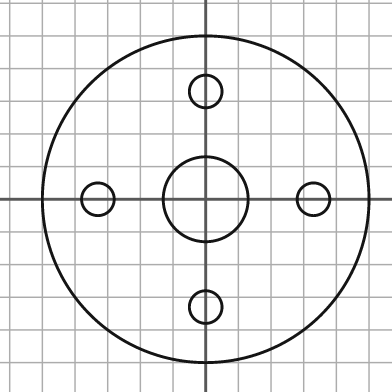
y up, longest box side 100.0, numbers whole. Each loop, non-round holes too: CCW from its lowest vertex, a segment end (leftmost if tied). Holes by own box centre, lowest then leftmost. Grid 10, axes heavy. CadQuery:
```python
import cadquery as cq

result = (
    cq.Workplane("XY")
    .moveTo(0.0, 0.0)
    .circle(50.0)
    .moveTo(0.0, -33.0)
    .circle(5.0)
    .moveTo(-33.0, 0.0)
    .circle(5.0)
    .moveTo(0.0, 0.0)
    .circle(13.0)
    .moveTo(33.0, 0.0)
    .circle(5.0)
    .moveTo(0.0, 33.0)
    .circle(5.0)
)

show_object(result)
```